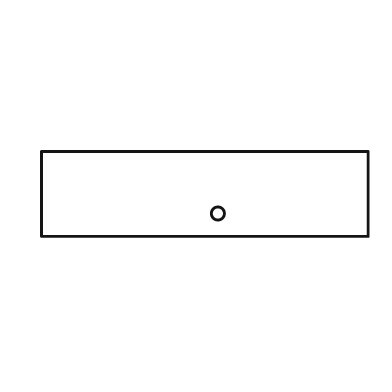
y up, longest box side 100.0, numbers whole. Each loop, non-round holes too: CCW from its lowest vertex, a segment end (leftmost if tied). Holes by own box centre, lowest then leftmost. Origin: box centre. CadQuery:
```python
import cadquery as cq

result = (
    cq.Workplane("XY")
    .moveTo(-50.0, -13.0)
    .lineTo(50.0, -13.0)
    .lineTo(50.0, 13.0)
    .lineTo(-50.0, 13.0)
    .close()
    .moveTo(4.0, -6.0)
    .circle(2.0)
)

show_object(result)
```